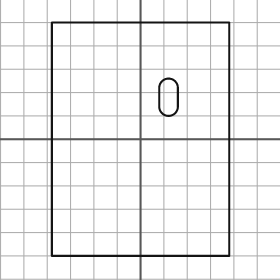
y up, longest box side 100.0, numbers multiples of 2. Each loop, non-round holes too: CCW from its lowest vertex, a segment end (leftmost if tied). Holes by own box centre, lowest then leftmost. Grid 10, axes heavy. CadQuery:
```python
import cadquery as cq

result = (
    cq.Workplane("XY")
    .moveTo(-38.0, -50.0)
    .lineTo(38.0, -50.0)
    .lineTo(38.0, 50.0)
    .lineTo(-38.0, 50.0)
    .close()
    .moveTo(8.0, 14.0)
    .threePointArc((12.0, 10.0), (16.0, 14.0))
    .lineTo(16.0, 22.0)
    .threePointArc((12.0, 26.0), (8.0, 22.0))
    .close()
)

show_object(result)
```